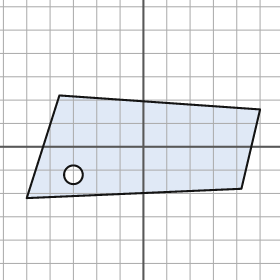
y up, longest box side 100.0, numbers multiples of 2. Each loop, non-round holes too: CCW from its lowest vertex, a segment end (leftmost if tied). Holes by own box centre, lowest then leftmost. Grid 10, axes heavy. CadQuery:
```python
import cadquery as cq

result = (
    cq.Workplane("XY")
    .moveTo(-50.0, -22.0)
    .lineTo(42.0, -18.0)
    .lineTo(50.0, 16.0)
    .lineTo(-36.0, 22.0)
    .close()
    .moveTo(-30.0, -12.0)
    .circle(4.0)
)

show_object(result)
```